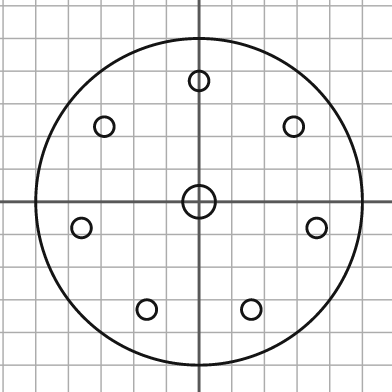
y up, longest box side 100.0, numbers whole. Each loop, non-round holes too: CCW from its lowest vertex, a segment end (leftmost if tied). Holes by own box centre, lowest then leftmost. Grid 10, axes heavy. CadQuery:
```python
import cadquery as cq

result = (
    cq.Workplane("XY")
    .moveTo(0.0, 0.0)
    .circle(50.0)
    .moveTo(-16.0, -33.0)
    .circle(3.0)
    .moveTo(16.0, -33.0)
    .circle(3.0)
    .moveTo(-36.0, -8.0)
    .circle(3.0)
    .moveTo(36.0, -8.0)
    .circle(3.0)
    .moveTo(0.0, 0.0)
    .circle(5.0)
    .moveTo(-29.0, 23.0)
    .circle(3.0)
    .moveTo(29.0, 23.0)
    .circle(3.0)
    .moveTo(0.0, 37.0)
    .circle(3.0)
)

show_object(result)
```